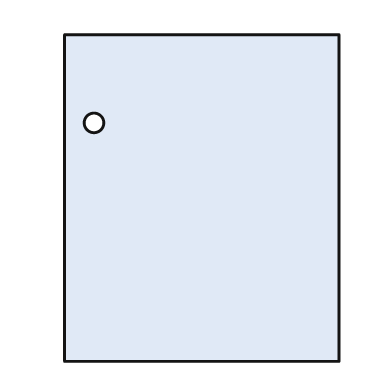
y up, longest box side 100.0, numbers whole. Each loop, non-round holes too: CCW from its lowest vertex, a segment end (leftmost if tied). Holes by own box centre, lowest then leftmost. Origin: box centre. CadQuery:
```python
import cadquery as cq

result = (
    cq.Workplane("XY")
    .moveTo(-42.0, -50.0)
    .lineTo(42.0, -50.0)
    .lineTo(42.0, 50.0)
    .lineTo(-42.0, 50.0)
    .close()
    .moveTo(-33.0, 23.0)
    .circle(3.0)
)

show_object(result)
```